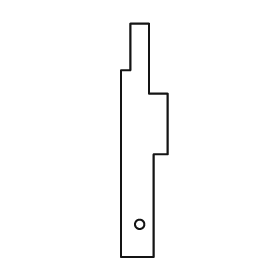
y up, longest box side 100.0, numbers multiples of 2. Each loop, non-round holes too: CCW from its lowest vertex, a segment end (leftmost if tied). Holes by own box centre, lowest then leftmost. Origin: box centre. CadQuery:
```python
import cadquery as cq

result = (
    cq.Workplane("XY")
    .moveTo(-10.0, -50.0)
    .lineTo(4.0, -50.0)
    .lineTo(4.0, -6.0)
    .lineTo(10.0, -6.0)
    .lineTo(10.0, 20.0)
    .lineTo(2.0, 20.0)
    .lineTo(2.0, 50.0)
    .lineTo(-6.0, 50.0)
    .lineTo(-6.0, 30.0)
    .lineTo(-10.0, 30.0)
    .close()
    .moveTo(-2.0, -36.0)
    .circle(2.0)
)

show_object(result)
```